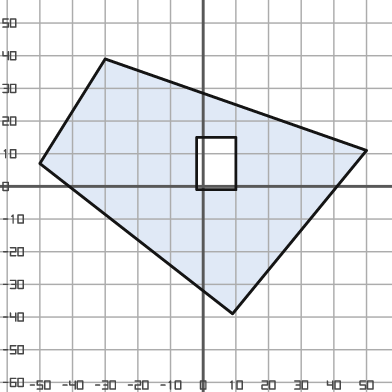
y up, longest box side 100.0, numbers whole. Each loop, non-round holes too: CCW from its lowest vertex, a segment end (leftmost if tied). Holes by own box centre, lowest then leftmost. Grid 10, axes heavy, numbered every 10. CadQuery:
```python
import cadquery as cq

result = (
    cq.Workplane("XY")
    .moveTo(9.0, -39.0)
    .lineTo(50.0, 11.0)
    .lineTo(-30.0, 39.0)
    .lineTo(-50.0, 7.0)
    .close()
    .moveTo(-2.0, -1.0)
    .lineTo(10.0, -1.0)
    .lineTo(10.0, 15.0)
    .lineTo(-2.0, 15.0)
    .close()
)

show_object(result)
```